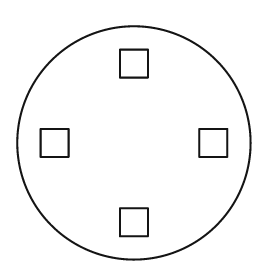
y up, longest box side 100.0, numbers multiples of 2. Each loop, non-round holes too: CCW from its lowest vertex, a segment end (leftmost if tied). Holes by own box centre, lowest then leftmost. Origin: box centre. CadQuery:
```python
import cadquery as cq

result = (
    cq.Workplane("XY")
    .moveTo(0.0, 0.0)
    .circle(50.0)
    .moveTo(-6.0, -40.0)
    .lineTo(6.0, -40.0)
    .lineTo(6.0, -28.0)
    .lineTo(-6.0, -28.0)
    .close()
    .moveTo(-40.0, -6.0)
    .lineTo(-28.0, -6.0)
    .lineTo(-28.0, 6.0)
    .lineTo(-40.0, 6.0)
    .close()
    .moveTo(28.0, -6.0)
    .lineTo(40.0, -6.0)
    .lineTo(40.0, 6.0)
    .lineTo(28.0, 6.0)
    .close()
    .moveTo(-6.0, 28.0)
    .lineTo(6.0, 28.0)
    .lineTo(6.0, 40.0)
    .lineTo(-6.0, 40.0)
    .close()
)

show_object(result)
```